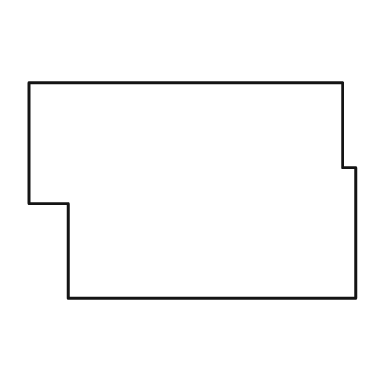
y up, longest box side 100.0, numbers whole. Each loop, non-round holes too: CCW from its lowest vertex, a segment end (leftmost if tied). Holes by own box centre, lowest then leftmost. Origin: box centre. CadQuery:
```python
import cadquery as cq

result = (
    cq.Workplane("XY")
    .moveTo(-38.0, -33.0)
    .lineTo(50.0, -33.0)
    .lineTo(50.0, 7.0)
    .lineTo(46.0, 7.0)
    .lineTo(46.0, 33.0)
    .lineTo(-50.0, 33.0)
    .lineTo(-50.0, -4.0)
    .lineTo(-38.0, -4.0)
    .close()
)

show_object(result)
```